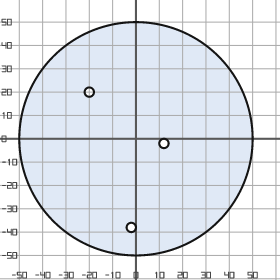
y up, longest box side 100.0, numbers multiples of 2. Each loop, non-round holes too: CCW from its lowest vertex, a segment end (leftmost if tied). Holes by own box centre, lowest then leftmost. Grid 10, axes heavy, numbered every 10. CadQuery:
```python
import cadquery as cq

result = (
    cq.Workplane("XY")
    .moveTo(0.0, 0.0)
    .circle(50.0)
    .moveTo(-2.0, -38.0)
    .circle(2.0)
    .moveTo(12.0, -2.0)
    .circle(2.0)
    .moveTo(-20.0, 20.0)
    .circle(2.0)
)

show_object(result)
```